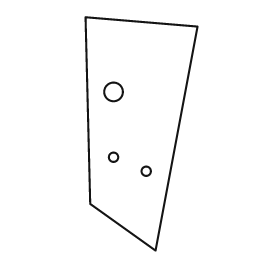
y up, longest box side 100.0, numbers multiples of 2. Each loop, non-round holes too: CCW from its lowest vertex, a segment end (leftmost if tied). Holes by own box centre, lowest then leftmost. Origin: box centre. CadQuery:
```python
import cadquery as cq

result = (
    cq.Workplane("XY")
    .moveTo(6.0, -50.0)
    .lineTo(24.0, 46.0)
    .lineTo(-24.0, 50.0)
    .lineTo(-22.0, -30.0)
    .close()
    .moveTo(2.0, -16.0)
    .circle(2.0)
    .moveTo(-12.0, -10.0)
    .circle(2.0)
    .moveTo(-12.0, 18.0)
    .circle(4.0)
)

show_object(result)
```